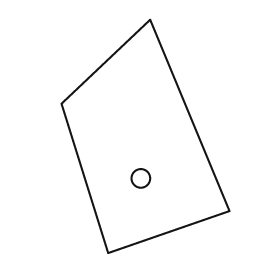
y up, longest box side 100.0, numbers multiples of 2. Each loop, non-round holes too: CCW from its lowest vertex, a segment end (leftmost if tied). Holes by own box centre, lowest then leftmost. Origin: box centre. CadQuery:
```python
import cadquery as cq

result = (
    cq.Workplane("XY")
    .moveTo(-16.0, -50.0)
    .lineTo(36.0, -32.0)
    .lineTo(2.0, 50.0)
    .lineTo(-36.0, 14.0)
    .close()
    .moveTo(-2.0, -18.0)
    .circle(4.0)
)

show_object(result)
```